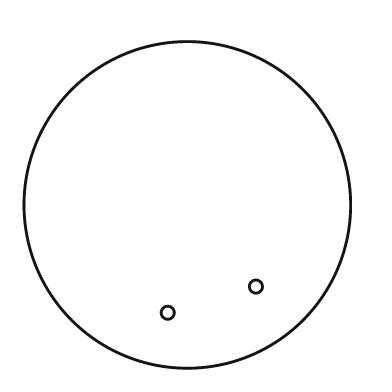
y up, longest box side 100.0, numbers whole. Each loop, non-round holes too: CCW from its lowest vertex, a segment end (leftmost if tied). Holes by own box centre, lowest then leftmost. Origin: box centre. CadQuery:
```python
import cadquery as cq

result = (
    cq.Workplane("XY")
    .moveTo(0.0, 0.0)
    .circle(50.0)
    .moveTo(-6.0, -33.0)
    .circle(2.0)
    .moveTo(21.0, -25.0)
    .circle(2.0)
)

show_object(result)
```